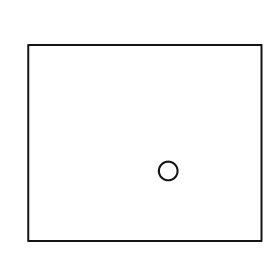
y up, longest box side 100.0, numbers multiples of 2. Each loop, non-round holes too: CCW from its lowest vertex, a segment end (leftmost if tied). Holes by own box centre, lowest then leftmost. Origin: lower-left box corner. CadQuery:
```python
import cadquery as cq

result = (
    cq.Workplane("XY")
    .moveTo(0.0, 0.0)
    .lineTo(100.0, 0.0)
    .lineTo(100.0, 84.0)
    .lineTo(0.0, 84.0)
    .close()
    .moveTo(60.0, 30.0)
    .circle(4.0)
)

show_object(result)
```